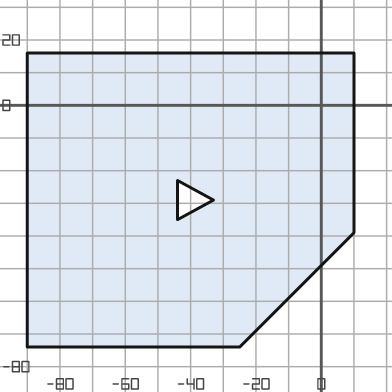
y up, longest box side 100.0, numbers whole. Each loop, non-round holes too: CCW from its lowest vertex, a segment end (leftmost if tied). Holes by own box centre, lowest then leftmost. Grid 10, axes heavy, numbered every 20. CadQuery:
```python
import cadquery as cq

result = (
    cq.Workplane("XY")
    .moveTo(-90.0, -74.0)
    .lineTo(-25.0, -74.0)
    .lineTo(10.0, -39.0)
    .lineTo(10.0, 16.0)
    .lineTo(-90.0, 16.0)
    .close()
    .moveTo(-44.0, -35.0)
    .lineTo(-33.0, -29.0)
    .lineTo(-44.0, -23.0)
    .close()
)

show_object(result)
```